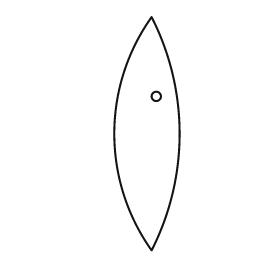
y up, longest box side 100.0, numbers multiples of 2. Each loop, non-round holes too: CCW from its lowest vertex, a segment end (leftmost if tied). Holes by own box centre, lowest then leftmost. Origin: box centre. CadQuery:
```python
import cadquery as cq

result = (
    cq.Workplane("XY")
    .moveTo(2.0, -50.0)
    .threePointArc((14.0, 0.0), (2.0, 50.0))
    .threePointArc((-14.0, 0.0), (2.0, -50.0))
    .close()
    .moveTo(4.0, 16.0)
    .circle(2.0)
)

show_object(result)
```